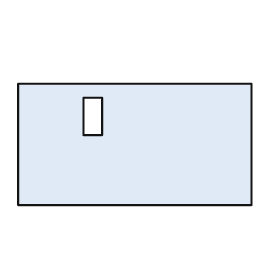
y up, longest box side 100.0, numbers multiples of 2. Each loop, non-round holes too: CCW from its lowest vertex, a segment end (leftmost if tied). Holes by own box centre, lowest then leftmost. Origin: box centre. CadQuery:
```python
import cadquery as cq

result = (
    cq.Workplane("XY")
    .moveTo(-50.0, -26.0)
    .lineTo(50.0, -26.0)
    .lineTo(50.0, 26.0)
    .lineTo(-50.0, 26.0)
    .close()
    .moveTo(-22.0, 4.0)
    .lineTo(-14.0, 4.0)
    .lineTo(-14.0, 20.0)
    .lineTo(-22.0, 20.0)
    .close()
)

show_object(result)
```